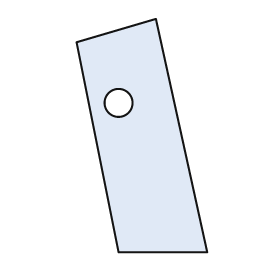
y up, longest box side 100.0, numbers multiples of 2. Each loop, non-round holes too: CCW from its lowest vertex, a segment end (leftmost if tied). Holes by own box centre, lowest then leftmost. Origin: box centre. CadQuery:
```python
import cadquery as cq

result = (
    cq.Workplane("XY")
    .moveTo(-10.0, -50.0)
    .lineTo(28.0, -50.0)
    .lineTo(6.0, 50.0)
    .lineTo(-28.0, 40.0)
    .close()
    .moveTo(-10.0, 14.0)
    .circle(6.0)
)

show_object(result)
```